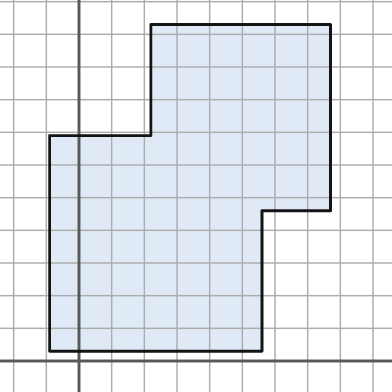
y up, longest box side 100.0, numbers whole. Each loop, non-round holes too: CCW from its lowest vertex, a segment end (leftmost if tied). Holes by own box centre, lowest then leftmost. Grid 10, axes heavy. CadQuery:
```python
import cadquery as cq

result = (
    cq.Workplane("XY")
    .moveTo(-9.0, 3.0)
    .lineTo(56.0, 3.0)
    .lineTo(56.0, 46.0)
    .lineTo(77.0, 46.0)
    .lineTo(77.0, 103.0)
    .lineTo(22.0, 103.0)
    .lineTo(22.0, 69.0)
    .lineTo(-9.0, 69.0)
    .close()
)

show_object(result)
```